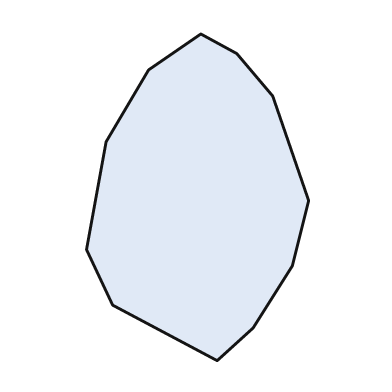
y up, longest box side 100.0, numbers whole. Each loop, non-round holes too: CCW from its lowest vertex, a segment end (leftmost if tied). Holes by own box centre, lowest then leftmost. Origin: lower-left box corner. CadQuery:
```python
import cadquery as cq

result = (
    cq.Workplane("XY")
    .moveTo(40.0, 0.0)
    .lineTo(51.0, 10.0)
    .lineTo(63.0, 29.0)
    .lineTo(68.0, 49.0)
    .lineTo(57.0, 81.0)
    .lineTo(46.0, 94.0)
    .lineTo(35.0, 100.0)
    .lineTo(19.0, 89.0)
    .lineTo(6.0, 67.0)
    .lineTo(0.0, 34.0)
    .lineTo(8.0, 17.0)
    .close()
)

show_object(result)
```